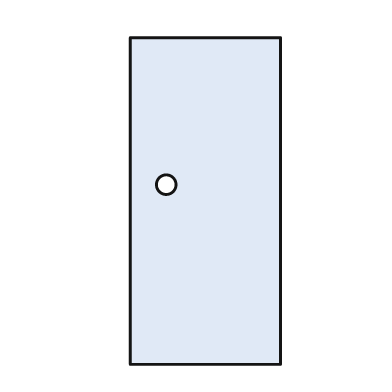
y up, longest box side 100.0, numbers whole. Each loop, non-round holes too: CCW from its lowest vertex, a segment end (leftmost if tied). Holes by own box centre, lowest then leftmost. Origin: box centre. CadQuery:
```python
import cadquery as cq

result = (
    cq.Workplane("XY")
    .moveTo(-23.0, -50.0)
    .lineTo(23.0, -50.0)
    .lineTo(23.0, 50.0)
    .lineTo(-23.0, 50.0)
    .close()
    .moveTo(-12.0, 5.0)
    .circle(3.0)
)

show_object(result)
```